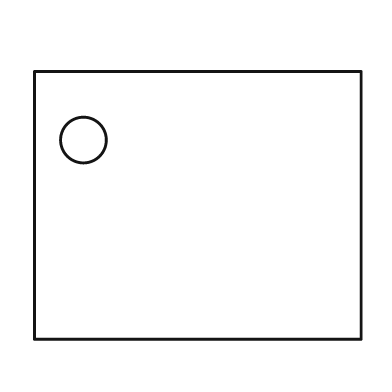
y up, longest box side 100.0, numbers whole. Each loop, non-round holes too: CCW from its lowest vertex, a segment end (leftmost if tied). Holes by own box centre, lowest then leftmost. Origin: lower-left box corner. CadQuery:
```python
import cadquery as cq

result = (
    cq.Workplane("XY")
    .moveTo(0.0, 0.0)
    .lineTo(100.0, 0.0)
    .lineTo(100.0, 82.0)
    .lineTo(0.0, 82.0)
    .close()
    .moveTo(15.0, 61.0)
    .circle(7.0)
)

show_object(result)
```